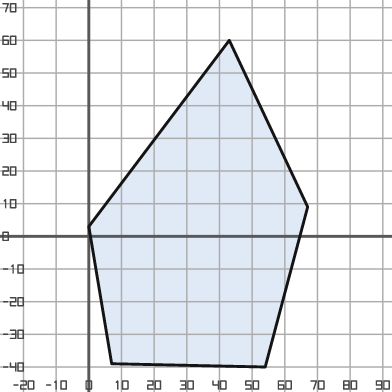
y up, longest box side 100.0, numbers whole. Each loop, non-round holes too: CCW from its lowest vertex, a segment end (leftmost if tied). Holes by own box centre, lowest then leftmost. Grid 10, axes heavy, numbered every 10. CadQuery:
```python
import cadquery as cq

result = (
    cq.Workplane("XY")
    .moveTo(54.0, -40.0)
    .lineTo(67.0, 9.0)
    .lineTo(43.0, 60.0)
    .lineTo(0.0, 3.0)
    .lineTo(7.0, -39.0)
    .close()
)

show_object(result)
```